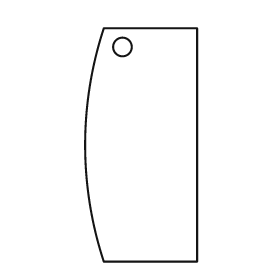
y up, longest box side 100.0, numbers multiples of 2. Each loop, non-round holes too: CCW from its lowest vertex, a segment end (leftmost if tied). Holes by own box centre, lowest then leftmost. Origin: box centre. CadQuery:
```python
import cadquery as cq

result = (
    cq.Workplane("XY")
    .moveTo(-16.0, -50.0)
    .lineTo(24.0, -50.0)
    .lineTo(24.0, 50.0)
    .lineTo(-16.0, 50.0)
    .threePointArc((-24.0, 0.0), (-16.0, -50.0))
    .close()
    .moveTo(-8.0, 42.0)
    .circle(4.0)
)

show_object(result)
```